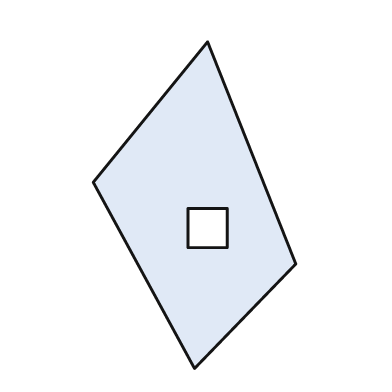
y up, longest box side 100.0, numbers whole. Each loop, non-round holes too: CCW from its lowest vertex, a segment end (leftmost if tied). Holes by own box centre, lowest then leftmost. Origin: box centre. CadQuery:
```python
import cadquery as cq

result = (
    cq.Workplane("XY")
    .moveTo(0.0, -50.0)
    .lineTo(31.0, -18.0)
    .lineTo(4.0, 50.0)
    .lineTo(-31.0, 7.0)
    .close()
    .moveTo(-2.0, -13.0)
    .lineTo(10.0, -13.0)
    .lineTo(10.0, -1.0)
    .lineTo(-2.0, -1.0)
    .close()
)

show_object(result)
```